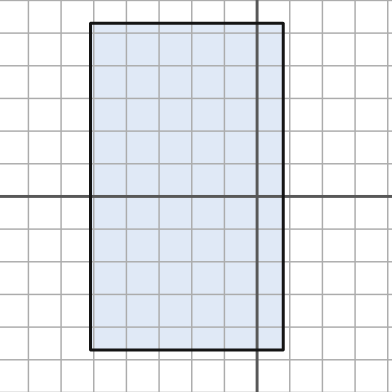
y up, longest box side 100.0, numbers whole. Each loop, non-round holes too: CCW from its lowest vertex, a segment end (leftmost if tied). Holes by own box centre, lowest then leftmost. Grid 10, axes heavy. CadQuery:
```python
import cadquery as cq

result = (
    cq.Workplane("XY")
    .moveTo(-51.0, -47.0)
    .lineTo(8.0, -47.0)
    .lineTo(8.0, 53.0)
    .lineTo(-51.0, 53.0)
    .close()
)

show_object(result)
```